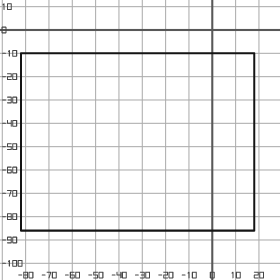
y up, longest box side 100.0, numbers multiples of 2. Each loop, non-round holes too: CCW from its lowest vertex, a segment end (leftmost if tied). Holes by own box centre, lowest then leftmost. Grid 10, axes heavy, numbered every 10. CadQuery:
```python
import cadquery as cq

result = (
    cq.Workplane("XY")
    .moveTo(-82.0, -86.0)
    .lineTo(18.0, -86.0)
    .lineTo(18.0, -10.0)
    .lineTo(-82.0, -10.0)
    .close()
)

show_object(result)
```